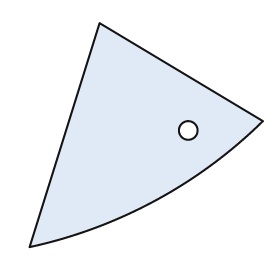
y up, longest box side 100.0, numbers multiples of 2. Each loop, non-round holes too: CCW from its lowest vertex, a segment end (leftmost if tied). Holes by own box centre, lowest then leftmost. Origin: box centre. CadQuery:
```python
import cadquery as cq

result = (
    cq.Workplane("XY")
    .moveTo(-50.0, -48.0)
    .threePointArc((4.0, -28.0), (50.0, 6.0))
    .lineTo(-20.0, 48.0)
    .close()
    .moveTo(18.0, 2.0)
    .circle(4.0)
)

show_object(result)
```